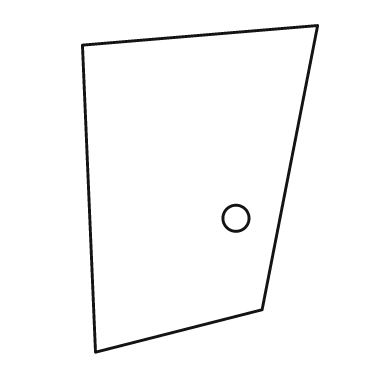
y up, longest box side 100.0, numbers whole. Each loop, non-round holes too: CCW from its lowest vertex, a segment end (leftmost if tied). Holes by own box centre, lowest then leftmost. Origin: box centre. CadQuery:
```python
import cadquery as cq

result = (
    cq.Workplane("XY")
    .moveTo(-32.0, -50.0)
    .lineTo(19.0, -37.0)
    .lineTo(36.0, 50.0)
    .lineTo(-36.0, 44.0)
    .close()
    .moveTo(11.0, -9.0)
    .circle(4.0)
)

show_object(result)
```